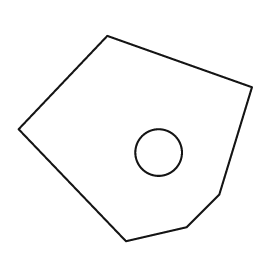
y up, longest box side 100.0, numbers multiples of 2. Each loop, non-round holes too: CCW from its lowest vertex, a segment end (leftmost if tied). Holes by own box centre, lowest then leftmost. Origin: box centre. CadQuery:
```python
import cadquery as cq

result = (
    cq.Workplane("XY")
    .moveTo(-4.0, -44.0)
    .lineTo(22.0, -38.0)
    .lineTo(36.0, -24.0)
    .lineTo(50.0, 22.0)
    .lineTo(-12.0, 44.0)
    .lineTo(-50.0, 4.0)
    .close()
    .moveTo(10.0, -6.0)
    .circle(10.0)
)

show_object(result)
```